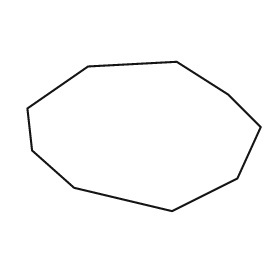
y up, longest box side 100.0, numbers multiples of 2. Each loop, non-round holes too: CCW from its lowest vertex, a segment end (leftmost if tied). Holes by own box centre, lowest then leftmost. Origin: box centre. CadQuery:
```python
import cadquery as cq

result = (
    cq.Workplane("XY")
    .moveTo(12.0, -32.0)
    .lineTo(40.0, -18.0)
    .lineTo(50.0, 4.0)
    .lineTo(36.0, 18.0)
    .lineTo(14.0, 32.0)
    .lineTo(-24.0, 30.0)
    .lineTo(-50.0, 12.0)
    .lineTo(-48.0, -6.0)
    .lineTo(-30.0, -22.0)
    .close()
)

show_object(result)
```